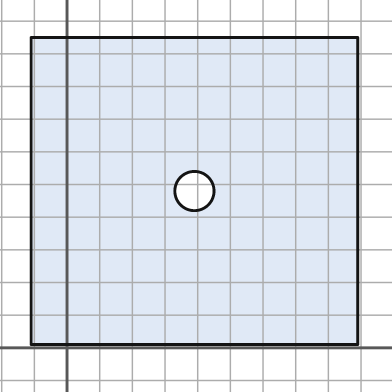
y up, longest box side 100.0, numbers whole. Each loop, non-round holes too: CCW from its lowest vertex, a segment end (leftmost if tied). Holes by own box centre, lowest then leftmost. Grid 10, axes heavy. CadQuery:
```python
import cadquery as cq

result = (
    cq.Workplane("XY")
    .moveTo(-11.0, 1.0)
    .lineTo(89.0, 1.0)
    .lineTo(89.0, 95.0)
    .lineTo(-11.0, 95.0)
    .close()
    .moveTo(39.0, 48.0)
    .circle(6.0)
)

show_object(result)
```